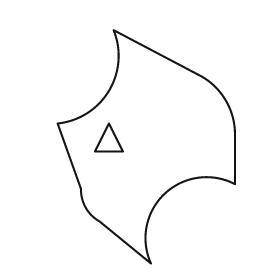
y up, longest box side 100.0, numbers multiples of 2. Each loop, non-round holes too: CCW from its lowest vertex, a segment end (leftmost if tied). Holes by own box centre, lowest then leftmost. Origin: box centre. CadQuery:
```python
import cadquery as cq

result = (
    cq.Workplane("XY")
    .moveTo(2.0, -50.0)
    .threePointArc((8.0, -20.0), (38.0, -16.0))
    .lineTo(38.0, 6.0)
    .threePointArc((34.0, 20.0), (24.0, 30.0))
    .lineTo(-14.0, 50.0)
    .threePointArc((-16.0, 24.0), (-38.0, 10.0))
    .lineTo(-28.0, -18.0)
    .threePointArc((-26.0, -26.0), (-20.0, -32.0))
    .close()
    .moveTo(-22.0, -2.0)
    .lineTo(-10.0, -2.0)
    .lineTo(-16.0, 10.0)
    .close()
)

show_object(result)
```